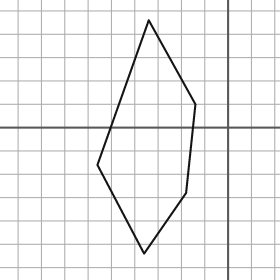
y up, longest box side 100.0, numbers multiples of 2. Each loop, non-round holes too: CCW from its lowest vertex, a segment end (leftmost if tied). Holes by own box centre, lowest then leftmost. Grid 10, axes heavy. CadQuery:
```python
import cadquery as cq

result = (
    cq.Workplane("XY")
    .moveTo(-36.0, -54.0)
    .lineTo(-18.0, -28.0)
    .lineTo(-14.0, 10.0)
    .lineTo(-34.0, 46.0)
    .lineTo(-56.0, -16.0)
    .close()
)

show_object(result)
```